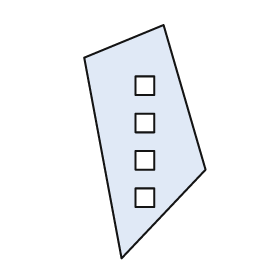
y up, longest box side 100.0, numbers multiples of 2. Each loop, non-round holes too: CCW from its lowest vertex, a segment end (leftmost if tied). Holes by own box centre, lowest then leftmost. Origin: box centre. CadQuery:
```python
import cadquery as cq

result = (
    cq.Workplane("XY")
    .moveTo(-10.0, -50.0)
    .lineTo(26.0, -12.0)
    .lineTo(8.0, 50.0)
    .lineTo(-26.0, 36.0)
    .close()
    .moveTo(-4.0, -28.0)
    .lineTo(4.0, -28.0)
    .lineTo(4.0, -20.0)
    .lineTo(-4.0, -20.0)
    .close()
    .moveTo(-4.0, -12.0)
    .lineTo(4.0, -12.0)
    .lineTo(4.0, -4.0)
    .lineTo(-4.0, -4.0)
    .close()
    .moveTo(-4.0, 4.0)
    .lineTo(4.0, 4.0)
    .lineTo(4.0, 12.0)
    .lineTo(-4.0, 12.0)
    .close()
    .moveTo(-4.0, 20.0)
    .lineTo(4.0, 20.0)
    .lineTo(4.0, 28.0)
    .lineTo(-4.0, 28.0)
    .close()
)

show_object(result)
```